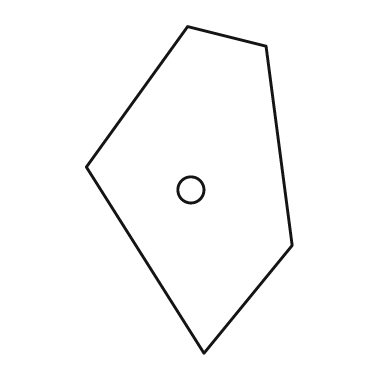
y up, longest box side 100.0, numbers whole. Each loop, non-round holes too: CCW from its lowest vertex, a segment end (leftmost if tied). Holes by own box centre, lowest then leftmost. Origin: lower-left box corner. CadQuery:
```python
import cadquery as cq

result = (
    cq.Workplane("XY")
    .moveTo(36.0, 0.0)
    .lineTo(63.0, 33.0)
    .lineTo(55.0, 94.0)
    .lineTo(31.0, 100.0)
    .lineTo(0.0, 57.0)
    .close()
    .moveTo(32.0, 50.0)
    .circle(4.0)
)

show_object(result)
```